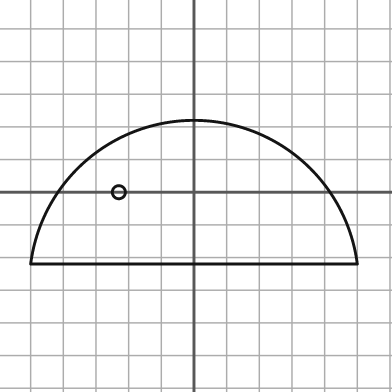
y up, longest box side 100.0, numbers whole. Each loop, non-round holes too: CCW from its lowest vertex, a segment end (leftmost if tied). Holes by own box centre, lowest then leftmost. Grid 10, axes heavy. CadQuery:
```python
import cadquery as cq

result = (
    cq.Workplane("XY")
    .moveTo(-50.0, -22.0)
    .lineTo(50.0, -22.0)
    .threePointArc((0.0, 22.0), (-50.0, -22.0))
    .close()
    .moveTo(-23.0, 0.0)
    .circle(2.0)
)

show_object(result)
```